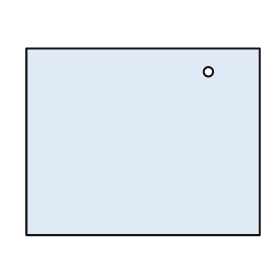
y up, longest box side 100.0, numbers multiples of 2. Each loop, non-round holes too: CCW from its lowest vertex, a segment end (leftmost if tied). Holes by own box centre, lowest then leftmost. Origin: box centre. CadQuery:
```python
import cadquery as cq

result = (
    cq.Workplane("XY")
    .moveTo(-50.0, -40.0)
    .lineTo(50.0, -40.0)
    .lineTo(50.0, 40.0)
    .lineTo(-50.0, 40.0)
    .close()
    .moveTo(28.0, 30.0)
    .circle(2.0)
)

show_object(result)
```